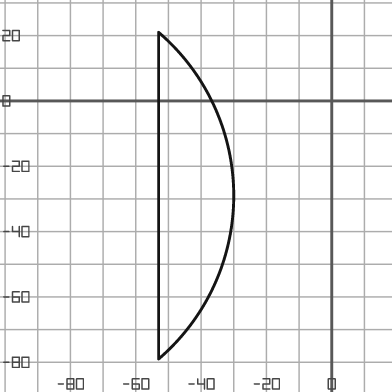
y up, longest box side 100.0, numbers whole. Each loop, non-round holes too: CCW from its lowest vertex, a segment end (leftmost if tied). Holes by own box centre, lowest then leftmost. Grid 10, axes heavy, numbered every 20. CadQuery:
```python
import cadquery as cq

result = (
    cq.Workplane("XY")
    .moveTo(-53.0, -79.0)
    .threePointArc((-30.0, -29.0), (-53.0, 21.0))
    .close()
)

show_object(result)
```